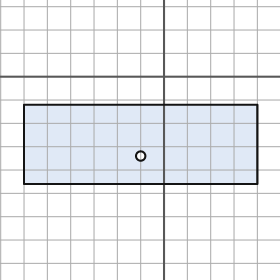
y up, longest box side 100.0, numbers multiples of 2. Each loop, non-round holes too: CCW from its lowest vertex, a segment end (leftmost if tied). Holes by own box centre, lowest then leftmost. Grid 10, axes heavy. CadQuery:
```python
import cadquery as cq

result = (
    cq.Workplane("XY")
    .moveTo(-60.0, -46.0)
    .lineTo(40.0, -46.0)
    .lineTo(40.0, -12.0)
    .lineTo(-60.0, -12.0)
    .close()
    .moveTo(-10.0, -34.0)
    .circle(2.0)
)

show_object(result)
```